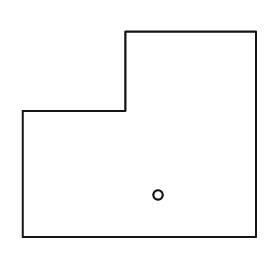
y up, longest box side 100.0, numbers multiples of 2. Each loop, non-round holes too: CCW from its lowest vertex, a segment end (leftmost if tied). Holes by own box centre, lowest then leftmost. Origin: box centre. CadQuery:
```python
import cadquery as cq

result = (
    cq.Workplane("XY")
    .moveTo(-50.0, -44.0)
    .lineTo(50.0, -44.0)
    .lineTo(50.0, 44.0)
    .lineTo(-6.0, 44.0)
    .lineTo(-6.0, 10.0)
    .lineTo(-50.0, 10.0)
    .close()
    .moveTo(8.0, -26.0)
    .circle(2.0)
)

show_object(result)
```